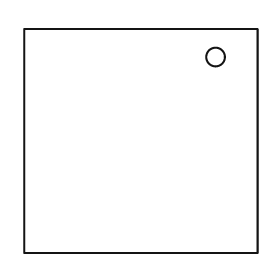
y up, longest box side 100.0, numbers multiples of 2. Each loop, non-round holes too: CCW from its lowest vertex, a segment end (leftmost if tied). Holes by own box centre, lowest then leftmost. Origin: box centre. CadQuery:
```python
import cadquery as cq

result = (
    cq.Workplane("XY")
    .moveTo(-50.0, -48.0)
    .lineTo(50.0, -48.0)
    .lineTo(50.0, 48.0)
    .lineTo(-50.0, 48.0)
    .close()
    .moveTo(32.0, 36.0)
    .circle(4.0)
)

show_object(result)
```